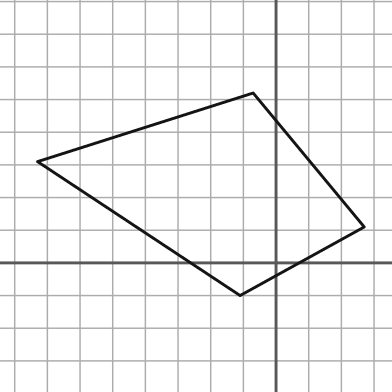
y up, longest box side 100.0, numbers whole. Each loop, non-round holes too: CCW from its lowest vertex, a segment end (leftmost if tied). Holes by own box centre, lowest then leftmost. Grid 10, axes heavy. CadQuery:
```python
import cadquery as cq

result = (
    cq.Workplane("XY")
    .moveTo(-11.0, -10.0)
    .lineTo(27.0, 11.0)
    .lineTo(-7.0, 52.0)
    .lineTo(-73.0, 31.0)
    .close()
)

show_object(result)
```